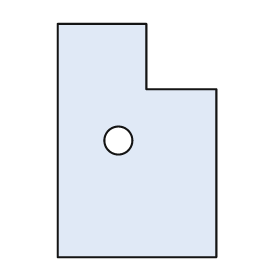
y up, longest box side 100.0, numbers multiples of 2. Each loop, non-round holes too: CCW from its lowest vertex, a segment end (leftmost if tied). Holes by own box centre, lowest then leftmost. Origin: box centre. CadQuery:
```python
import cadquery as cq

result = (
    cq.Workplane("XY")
    .moveTo(-34.0, -50.0)
    .lineTo(34.0, -50.0)
    .lineTo(34.0, 22.0)
    .lineTo(4.0, 22.0)
    .lineTo(4.0, 50.0)
    .lineTo(-34.0, 50.0)
    .close()
    .moveTo(-8.0, 0.0)
    .circle(6.0)
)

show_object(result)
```